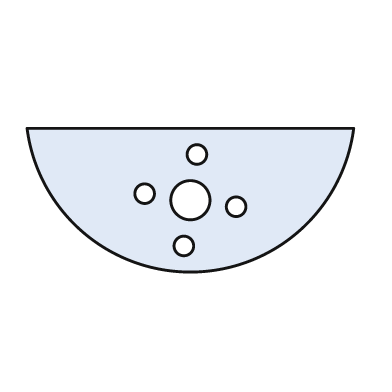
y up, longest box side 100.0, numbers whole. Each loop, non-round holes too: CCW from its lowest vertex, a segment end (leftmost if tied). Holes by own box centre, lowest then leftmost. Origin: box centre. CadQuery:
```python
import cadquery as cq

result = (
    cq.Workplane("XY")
    .moveTo(-50.0, 22.0)
    .threePointArc((0.0, -22.0), (50.0, 22.0))
    .close()
    .moveTo(-2.0, -14.0)
    .circle(3.0)
    .moveTo(14.0, -2.0)
    .circle(3.0)
    .moveTo(0.0, 0.0)
    .circle(6.0)
    .moveTo(-14.0, 2.0)
    .circle(3.0)
    .moveTo(2.0, 14.0)
    .circle(3.0)
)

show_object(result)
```